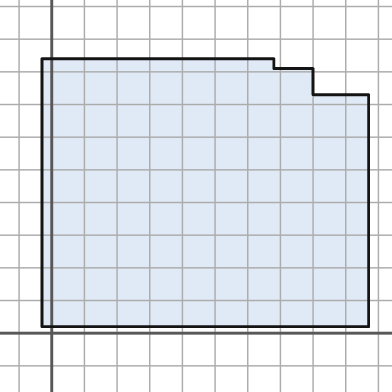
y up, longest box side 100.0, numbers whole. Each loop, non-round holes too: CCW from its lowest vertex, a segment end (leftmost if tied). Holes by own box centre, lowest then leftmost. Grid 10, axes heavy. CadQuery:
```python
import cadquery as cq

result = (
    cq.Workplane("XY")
    .moveTo(-3.0, 2.0)
    .lineTo(97.0, 2.0)
    .lineTo(97.0, 73.0)
    .lineTo(80.0, 73.0)
    .lineTo(80.0, 81.0)
    .lineTo(68.0, 81.0)
    .lineTo(68.0, 84.0)
    .lineTo(-3.0, 84.0)
    .close()
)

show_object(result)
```